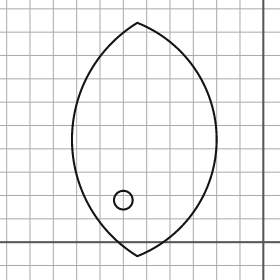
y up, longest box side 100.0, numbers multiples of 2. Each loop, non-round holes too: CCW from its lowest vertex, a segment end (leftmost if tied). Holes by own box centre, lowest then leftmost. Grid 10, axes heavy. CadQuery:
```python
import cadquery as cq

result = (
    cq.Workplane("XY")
    .moveTo(-54.0, -6.0)
    .threePointArc((-20.0, 44.0), (-54.0, 94.0))
    .threePointArc((-82.0, 44.0), (-54.0, -6.0))
    .close()
    .moveTo(-60.0, 18.0)
    .circle(4.0)
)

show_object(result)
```